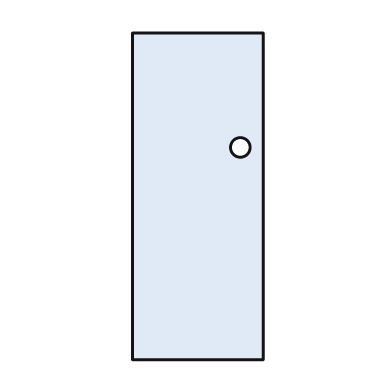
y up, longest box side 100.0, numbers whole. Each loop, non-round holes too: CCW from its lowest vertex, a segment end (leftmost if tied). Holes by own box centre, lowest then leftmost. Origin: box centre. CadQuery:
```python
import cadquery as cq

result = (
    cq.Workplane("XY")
    .moveTo(-20.0, -50.0)
    .lineTo(20.0, -50.0)
    .lineTo(20.0, 50.0)
    .lineTo(-20.0, 50.0)
    .close()
    .moveTo(13.0, 15.0)
    .circle(3.0)
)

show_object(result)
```